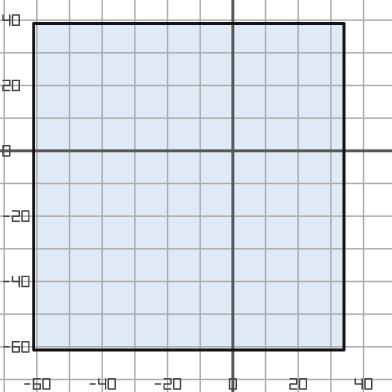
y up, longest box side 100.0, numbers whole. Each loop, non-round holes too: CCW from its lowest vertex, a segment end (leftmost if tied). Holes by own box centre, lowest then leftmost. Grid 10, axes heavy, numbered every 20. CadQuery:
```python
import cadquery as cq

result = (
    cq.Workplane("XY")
    .moveTo(-61.0, -61.0)
    .lineTo(34.0, -61.0)
    .lineTo(34.0, 39.0)
    .lineTo(-61.0, 39.0)
    .close()
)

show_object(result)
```